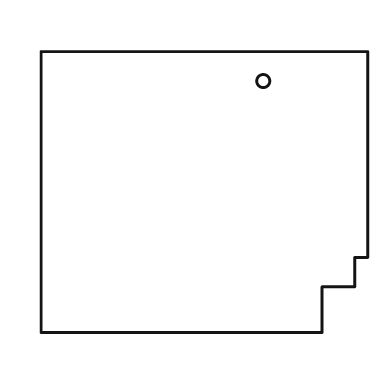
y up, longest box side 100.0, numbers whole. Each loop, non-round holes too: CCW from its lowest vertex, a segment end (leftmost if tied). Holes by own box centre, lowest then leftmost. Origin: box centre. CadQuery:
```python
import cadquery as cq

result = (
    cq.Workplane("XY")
    .moveTo(-50.0, -43.0)
    .lineTo(36.0, -43.0)
    .lineTo(36.0, -29.0)
    .lineTo(46.0, -29.0)
    .lineTo(46.0, -20.0)
    .lineTo(50.0, -20.0)
    .lineTo(50.0, 43.0)
    .lineTo(-50.0, 43.0)
    .close()
    .moveTo(18.0, 34.0)
    .circle(2.0)
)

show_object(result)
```